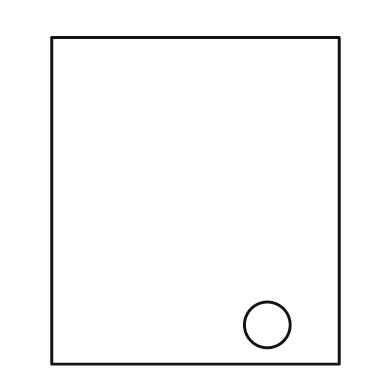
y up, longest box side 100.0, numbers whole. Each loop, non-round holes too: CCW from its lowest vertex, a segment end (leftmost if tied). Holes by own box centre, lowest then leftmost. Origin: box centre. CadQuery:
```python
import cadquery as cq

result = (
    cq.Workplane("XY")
    .moveTo(-44.0, -50.0)
    .lineTo(44.0, -50.0)
    .lineTo(44.0, 50.0)
    .lineTo(-44.0, 50.0)
    .close()
    .moveTo(22.0, -38.0)
    .circle(7.0)
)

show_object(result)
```